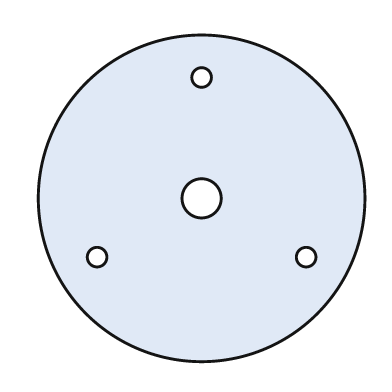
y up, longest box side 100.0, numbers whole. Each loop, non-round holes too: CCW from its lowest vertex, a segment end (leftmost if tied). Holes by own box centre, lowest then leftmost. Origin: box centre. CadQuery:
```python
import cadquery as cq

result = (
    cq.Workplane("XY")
    .moveTo(0.0, 0.0)
    .circle(50.0)
    .moveTo(-32.0, -18.0)
    .circle(3.0)
    .moveTo(32.0, -18.0)
    .circle(3.0)
    .moveTo(0.0, 0.0)
    .circle(6.0)
    .moveTo(0.0, 37.0)
    .circle(3.0)
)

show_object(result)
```